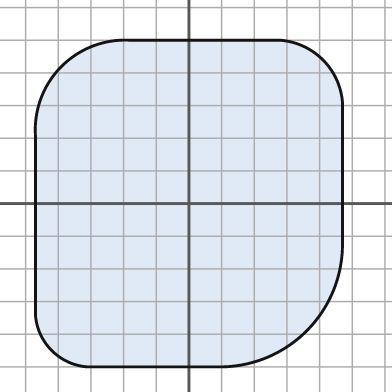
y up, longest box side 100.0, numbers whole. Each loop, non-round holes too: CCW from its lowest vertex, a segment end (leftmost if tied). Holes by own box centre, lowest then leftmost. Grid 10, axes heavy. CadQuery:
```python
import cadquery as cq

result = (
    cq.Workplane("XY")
    .moveTo(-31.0, -50.0)
    .lineTo(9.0, -50.0)
    .threePointArc((36.0, -39.0), (47.0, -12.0))
    .lineTo(47.0, 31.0)
    .threePointArc((41.0, 44.0), (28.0, 50.0))
    .lineTo(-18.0, 50.0)
    .threePointArc((-39.0, 42.0), (-47.0, 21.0))
    .lineTo(-47.0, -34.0)
    .threePointArc((-42.0, -45.0), (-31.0, -50.0))
    .close()
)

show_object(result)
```